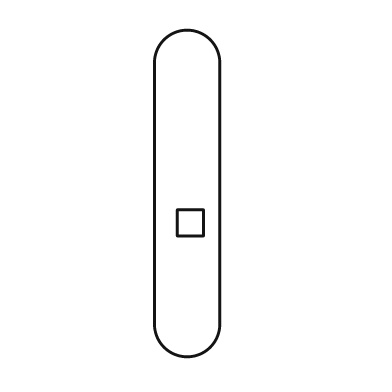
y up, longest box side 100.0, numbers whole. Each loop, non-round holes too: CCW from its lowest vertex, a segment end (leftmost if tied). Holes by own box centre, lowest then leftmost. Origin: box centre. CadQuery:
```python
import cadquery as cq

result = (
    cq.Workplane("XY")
    .moveTo(-10.0, -40.0)
    .threePointArc((0.0, -50.0), (10.0, -40.0))
    .lineTo(10.0, 40.0)
    .threePointArc((0.0, 50.0), (-10.0, 40.0))
    .close()
    .moveTo(-3.0, -13.0)
    .lineTo(5.0, -13.0)
    .lineTo(5.0, -5.0)
    .lineTo(-3.0, -5.0)
    .close()
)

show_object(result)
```